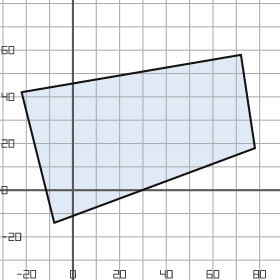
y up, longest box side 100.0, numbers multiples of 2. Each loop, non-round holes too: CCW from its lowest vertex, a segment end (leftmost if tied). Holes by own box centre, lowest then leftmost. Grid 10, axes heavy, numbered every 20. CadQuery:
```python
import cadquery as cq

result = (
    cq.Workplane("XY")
    .moveTo(-8.0, -14.0)
    .lineTo(78.0, 18.0)
    .lineTo(72.0, 58.0)
    .lineTo(-22.0, 42.0)
    .close()
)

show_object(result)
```